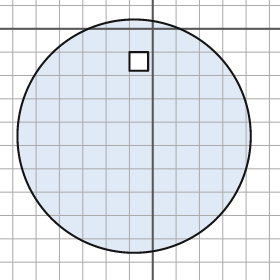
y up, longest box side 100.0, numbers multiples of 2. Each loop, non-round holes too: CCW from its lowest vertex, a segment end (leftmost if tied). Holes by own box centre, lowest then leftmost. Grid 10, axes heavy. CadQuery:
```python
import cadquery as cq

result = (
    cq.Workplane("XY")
    .moveTo(-8.0, -46.0)
    .circle(50.0)
    .moveTo(-10.0, -18.0)
    .lineTo(-2.0, -18.0)
    .lineTo(-2.0, -10.0)
    .lineTo(-10.0, -10.0)
    .close()
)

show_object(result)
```